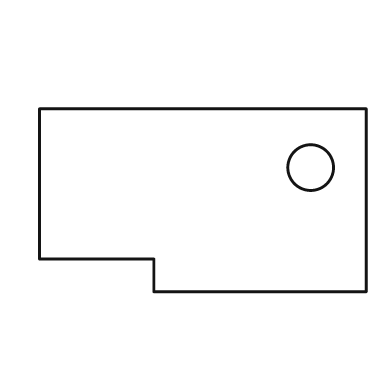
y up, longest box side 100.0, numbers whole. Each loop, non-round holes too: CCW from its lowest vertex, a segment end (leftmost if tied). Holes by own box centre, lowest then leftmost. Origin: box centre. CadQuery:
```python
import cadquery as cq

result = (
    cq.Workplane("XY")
    .moveTo(-15.0, -28.0)
    .lineTo(50.0, -28.0)
    .lineTo(50.0, 28.0)
    .lineTo(-50.0, 28.0)
    .lineTo(-50.0, -18.0)
    .lineTo(-15.0, -18.0)
    .close()
    .moveTo(33.0, 10.0)
    .circle(7.0)
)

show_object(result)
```